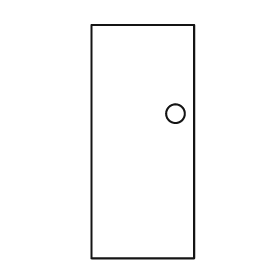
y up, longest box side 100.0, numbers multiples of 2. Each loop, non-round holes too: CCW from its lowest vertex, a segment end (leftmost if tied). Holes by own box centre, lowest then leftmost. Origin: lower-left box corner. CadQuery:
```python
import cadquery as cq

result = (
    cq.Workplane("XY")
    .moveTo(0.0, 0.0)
    .lineTo(44.0, 0.0)
    .lineTo(44.0, 100.0)
    .lineTo(0.0, 100.0)
    .close()
    .moveTo(36.0, 62.0)
    .circle(4.0)
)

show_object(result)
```